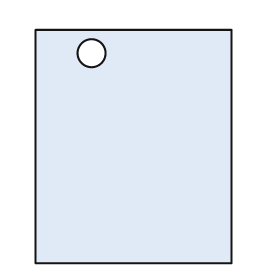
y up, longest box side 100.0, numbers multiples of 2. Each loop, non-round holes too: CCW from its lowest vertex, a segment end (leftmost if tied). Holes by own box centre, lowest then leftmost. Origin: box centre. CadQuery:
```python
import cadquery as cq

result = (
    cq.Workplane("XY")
    .moveTo(-42.0, -50.0)
    .lineTo(42.0, -50.0)
    .lineTo(42.0, 50.0)
    .lineTo(-42.0, 50.0)
    .close()
    .moveTo(-18.0, 40.0)
    .circle(6.0)
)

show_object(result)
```